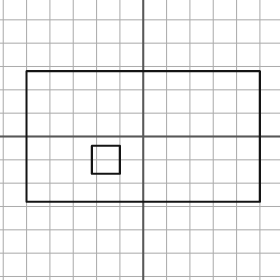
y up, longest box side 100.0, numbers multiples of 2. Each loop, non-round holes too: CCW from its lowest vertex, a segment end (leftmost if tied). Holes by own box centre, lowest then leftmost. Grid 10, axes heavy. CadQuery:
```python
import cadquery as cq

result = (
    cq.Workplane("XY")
    .moveTo(-50.0, -28.0)
    .lineTo(50.0, -28.0)
    .lineTo(50.0, 28.0)
    .lineTo(-50.0, 28.0)
    .close()
    .moveTo(-22.0, -16.0)
    .lineTo(-10.0, -16.0)
    .lineTo(-10.0, -4.0)
    .lineTo(-22.0, -4.0)
    .close()
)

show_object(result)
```